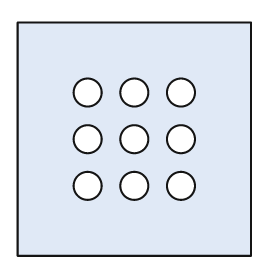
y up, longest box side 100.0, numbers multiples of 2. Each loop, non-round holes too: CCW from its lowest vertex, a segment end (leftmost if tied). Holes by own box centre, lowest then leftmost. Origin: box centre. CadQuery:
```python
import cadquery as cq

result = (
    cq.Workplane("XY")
    .moveTo(-50.0, -50.0)
    .lineTo(50.0, -50.0)
    .lineTo(50.0, 50.0)
    .lineTo(-50.0, 50.0)
    .close()
    .moveTo(-20.0, -20.0)
    .circle(6.0)
    .moveTo(0.0, -20.0)
    .circle(6.0)
    .moveTo(20.0, -20.0)
    .circle(6.0)
    .moveTo(-20.0, 0.0)
    .circle(6.0)
    .moveTo(0.0, 0.0)
    .circle(6.0)
    .moveTo(20.0, 0.0)
    .circle(6.0)
    .moveTo(-20.0, 20.0)
    .circle(6.0)
    .moveTo(0.0, 20.0)
    .circle(6.0)
    .moveTo(20.0, 20.0)
    .circle(6.0)
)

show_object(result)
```